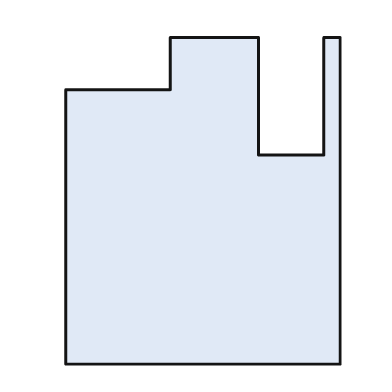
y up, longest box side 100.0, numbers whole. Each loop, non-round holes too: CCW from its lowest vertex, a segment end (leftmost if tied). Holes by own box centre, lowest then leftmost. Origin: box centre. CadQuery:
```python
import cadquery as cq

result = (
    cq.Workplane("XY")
    .moveTo(-42.0, -50.0)
    .lineTo(42.0, -50.0)
    .lineTo(42.0, 50.0)
    .lineTo(37.0, 50.0)
    .lineTo(37.0, 14.0)
    .lineTo(17.0, 14.0)
    .lineTo(17.0, 50.0)
    .lineTo(-10.0, 50.0)
    .lineTo(-10.0, 34.0)
    .lineTo(-42.0, 34.0)
    .close()
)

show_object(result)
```